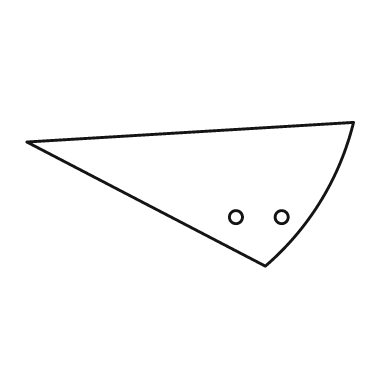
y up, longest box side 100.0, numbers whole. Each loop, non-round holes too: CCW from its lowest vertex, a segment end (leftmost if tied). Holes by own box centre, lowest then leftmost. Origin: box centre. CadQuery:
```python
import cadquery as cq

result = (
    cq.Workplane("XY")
    .moveTo(23.0, -22.0)
    .threePointArc((40.0, -2.0), (50.0, 22.0))
    .lineTo(-50.0, 16.0)
    .close()
    .moveTo(14.0, -7.0)
    .circle(2.0)
    .moveTo(28.0, -7.0)
    .circle(2.0)
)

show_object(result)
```